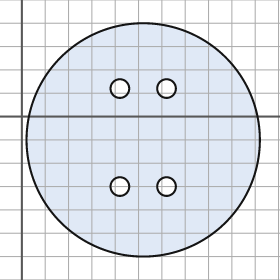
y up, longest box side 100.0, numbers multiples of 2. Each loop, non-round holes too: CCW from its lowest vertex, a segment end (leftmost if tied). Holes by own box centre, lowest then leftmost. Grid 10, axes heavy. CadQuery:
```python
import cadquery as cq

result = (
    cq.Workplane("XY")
    .moveTo(52.0, -10.0)
    .circle(50.0)
    .moveTo(42.0, -30.0)
    .circle(4.0)
    .moveTo(62.0, -30.0)
    .circle(4.0)
    .moveTo(42.0, 12.0)
    .circle(4.0)
    .moveTo(62.0, 12.0)
    .circle(4.0)
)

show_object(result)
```